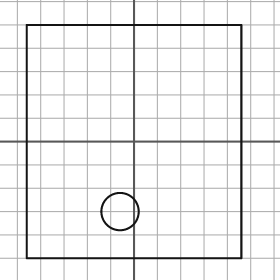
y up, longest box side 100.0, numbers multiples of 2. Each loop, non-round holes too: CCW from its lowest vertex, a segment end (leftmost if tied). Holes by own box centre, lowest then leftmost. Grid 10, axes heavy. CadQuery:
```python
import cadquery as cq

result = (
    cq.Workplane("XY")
    .moveTo(-46.0, -50.0)
    .lineTo(46.0, -50.0)
    .lineTo(46.0, 50.0)
    .lineTo(-46.0, 50.0)
    .close()
    .moveTo(-6.0, -30.0)
    .circle(8.0)
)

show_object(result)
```